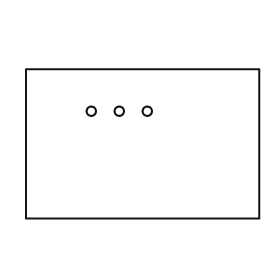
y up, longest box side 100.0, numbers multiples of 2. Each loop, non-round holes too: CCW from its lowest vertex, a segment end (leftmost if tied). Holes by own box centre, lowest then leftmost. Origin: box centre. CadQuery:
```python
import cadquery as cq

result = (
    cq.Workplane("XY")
    .moveTo(-50.0, -32.0)
    .lineTo(50.0, -32.0)
    .lineTo(50.0, 32.0)
    .lineTo(-50.0, 32.0)
    .close()
    .moveTo(-22.0, 14.0)
    .circle(2.0)
    .moveTo(-10.0, 14.0)
    .circle(2.0)
    .moveTo(2.0, 14.0)
    .circle(2.0)
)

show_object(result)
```